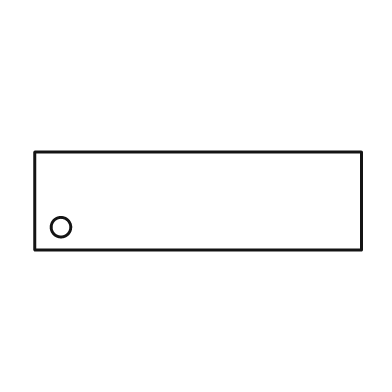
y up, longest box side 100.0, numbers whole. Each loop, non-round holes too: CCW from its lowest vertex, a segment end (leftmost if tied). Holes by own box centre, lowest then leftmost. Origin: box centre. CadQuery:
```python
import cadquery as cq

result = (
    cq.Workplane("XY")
    .moveTo(-50.0, -15.0)
    .lineTo(50.0, -15.0)
    .lineTo(50.0, 15.0)
    .lineTo(-50.0, 15.0)
    .close()
    .moveTo(-42.0, -8.0)
    .circle(3.0)
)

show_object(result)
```